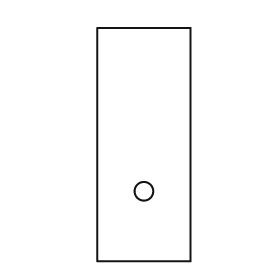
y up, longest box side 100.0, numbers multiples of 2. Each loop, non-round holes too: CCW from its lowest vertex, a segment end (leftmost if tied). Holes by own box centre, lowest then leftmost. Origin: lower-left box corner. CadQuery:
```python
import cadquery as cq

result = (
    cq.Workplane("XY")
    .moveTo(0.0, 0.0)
    .lineTo(40.0, 0.0)
    .lineTo(40.0, 100.0)
    .lineTo(0.0, 100.0)
    .close()
    .moveTo(20.0, 30.0)
    .circle(4.0)
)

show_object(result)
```